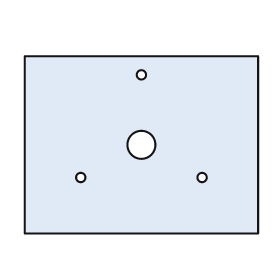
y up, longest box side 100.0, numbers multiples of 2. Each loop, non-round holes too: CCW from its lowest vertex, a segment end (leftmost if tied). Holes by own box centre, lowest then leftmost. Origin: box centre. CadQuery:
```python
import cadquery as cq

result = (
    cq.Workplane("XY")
    .moveTo(-50.0, -38.0)
    .lineTo(50.0, -38.0)
    .lineTo(50.0, 38.0)
    .lineTo(-50.0, 38.0)
    .close()
    .moveTo(-26.0, -14.0)
    .circle(2.0)
    .moveTo(26.0, -14.0)
    .circle(2.0)
    .moveTo(0.0, 0.0)
    .circle(6.0)
    .moveTo(0.0, 30.0)
    .circle(2.0)
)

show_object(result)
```